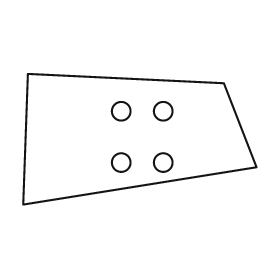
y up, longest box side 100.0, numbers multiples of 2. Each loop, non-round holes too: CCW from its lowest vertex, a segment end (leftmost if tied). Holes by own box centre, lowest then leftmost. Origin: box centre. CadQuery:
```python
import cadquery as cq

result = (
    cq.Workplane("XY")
    .moveTo(-50.0, -28.0)
    .lineTo(50.0, -12.0)
    .lineTo(36.0, 24.0)
    .lineTo(-48.0, 28.0)
    .close()
    .moveTo(-8.0, -10.0)
    .circle(4.0)
    .moveTo(10.0, -10.0)
    .circle(4.0)
    .moveTo(-8.0, 12.0)
    .circle(4.0)
    .moveTo(10.0, 12.0)
    .circle(4.0)
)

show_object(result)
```